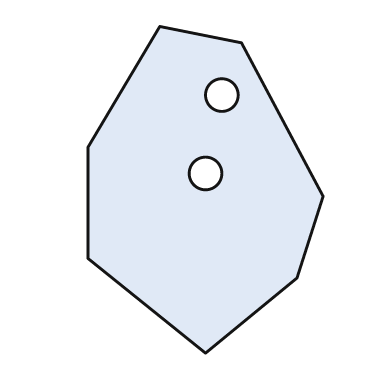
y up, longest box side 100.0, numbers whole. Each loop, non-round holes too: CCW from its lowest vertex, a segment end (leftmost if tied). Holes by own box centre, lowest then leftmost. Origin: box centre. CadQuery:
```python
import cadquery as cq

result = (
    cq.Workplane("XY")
    .moveTo(0.0, -50.0)
    .lineTo(28.0, -27.0)
    .lineTo(36.0, -2.0)
    .lineTo(11.0, 45.0)
    .lineTo(-14.0, 50.0)
    .lineTo(-36.0, 13.0)
    .lineTo(-36.0, -21.0)
    .close()
    .moveTo(0.0, 5.0)
    .circle(5.0)
    .moveTo(5.0, 29.0)
    .circle(5.0)
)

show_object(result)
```